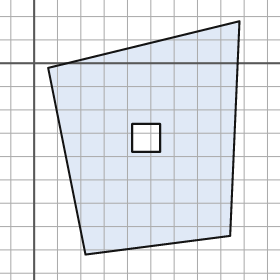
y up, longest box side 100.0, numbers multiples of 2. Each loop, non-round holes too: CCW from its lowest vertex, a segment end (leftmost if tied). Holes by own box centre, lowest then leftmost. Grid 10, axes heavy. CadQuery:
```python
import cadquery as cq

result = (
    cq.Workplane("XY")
    .moveTo(22.0, -82.0)
    .lineTo(84.0, -74.0)
    .lineTo(88.0, 18.0)
    .lineTo(6.0, -2.0)
    .close()
    .moveTo(42.0, -38.0)
    .lineTo(54.0, -38.0)
    .lineTo(54.0, -26.0)
    .lineTo(42.0, -26.0)
    .close()
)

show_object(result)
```